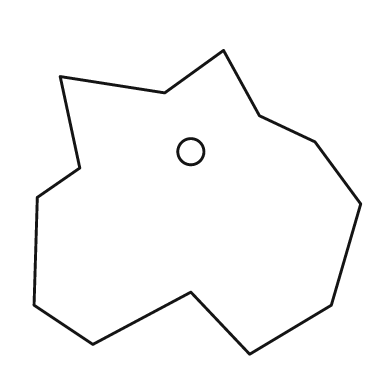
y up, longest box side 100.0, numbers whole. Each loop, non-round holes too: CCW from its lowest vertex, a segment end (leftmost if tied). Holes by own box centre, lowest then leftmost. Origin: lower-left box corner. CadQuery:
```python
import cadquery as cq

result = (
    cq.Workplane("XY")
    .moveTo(66.0, 0.0)
    .lineTo(91.0, 15.0)
    .lineTo(100.0, 46.0)
    .lineTo(86.0, 65.0)
    .lineTo(69.0, 73.0)
    .lineTo(58.0, 93.0)
    .lineTo(40.0, 80.0)
    .lineTo(8.0, 85.0)
    .lineTo(14.0, 57.0)
    .lineTo(1.0, 48.0)
    .lineTo(0.0, 15.0)
    .lineTo(18.0, 3.0)
    .lineTo(48.0, 19.0)
    .close()
    .moveTo(48.0, 62.0)
    .circle(4.0)
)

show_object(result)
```